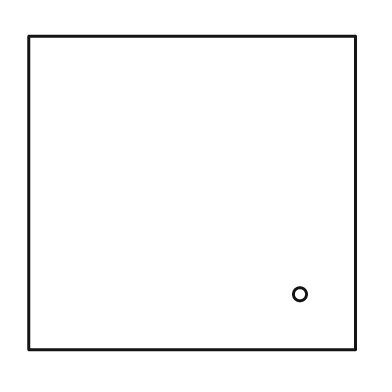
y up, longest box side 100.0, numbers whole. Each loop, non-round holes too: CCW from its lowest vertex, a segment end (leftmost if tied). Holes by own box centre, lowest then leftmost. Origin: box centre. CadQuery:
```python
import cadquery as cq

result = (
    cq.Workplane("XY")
    .moveTo(-50.0, -48.0)
    .lineTo(50.0, -48.0)
    .lineTo(50.0, 48.0)
    .lineTo(-50.0, 48.0)
    .close()
    .moveTo(33.0, -31.0)
    .circle(2.0)
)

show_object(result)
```